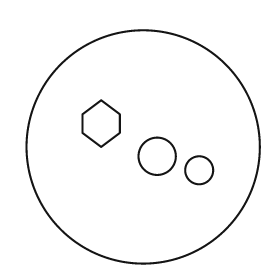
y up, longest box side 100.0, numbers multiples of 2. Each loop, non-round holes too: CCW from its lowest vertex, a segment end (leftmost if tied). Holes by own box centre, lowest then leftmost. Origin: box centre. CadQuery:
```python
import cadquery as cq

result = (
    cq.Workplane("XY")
    .moveTo(0.0, 0.0)
    .circle(50.0)
    .moveTo(24.0, -10.0)
    .circle(6.0)
    .moveTo(6.0, -4.0)
    .circle(8.0)
    .moveTo(-18.0, 0.0)
    .lineTo(-10.0, 6.0)
    .lineTo(-10.0, 14.0)
    .lineTo(-18.0, 20.0)
    .lineTo(-26.0, 14.0)
    .lineTo(-26.0, 6.0)
    .close()
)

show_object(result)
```